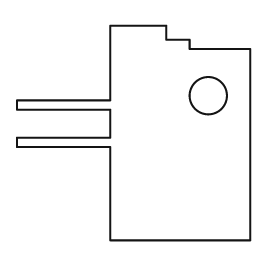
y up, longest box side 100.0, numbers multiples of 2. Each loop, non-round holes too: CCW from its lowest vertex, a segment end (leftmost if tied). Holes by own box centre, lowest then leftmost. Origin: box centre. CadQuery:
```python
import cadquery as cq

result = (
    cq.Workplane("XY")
    .moveTo(-10.0, -46.0)
    .lineTo(50.0, -46.0)
    .lineTo(50.0, 36.0)
    .lineTo(24.0, 36.0)
    .lineTo(24.0, 40.0)
    .lineTo(14.0, 40.0)
    .lineTo(14.0, 46.0)
    .lineTo(-10.0, 46.0)
    .lineTo(-10.0, 14.0)
    .lineTo(-50.0, 14.0)
    .lineTo(-50.0, 10.0)
    .lineTo(-10.0, 10.0)
    .lineTo(-10.0, -2.0)
    .lineTo(-50.0, -2.0)
    .lineTo(-50.0, -6.0)
    .lineTo(-10.0, -6.0)
    .close()
    .moveTo(32.0, 16.0)
    .circle(8.0)
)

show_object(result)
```